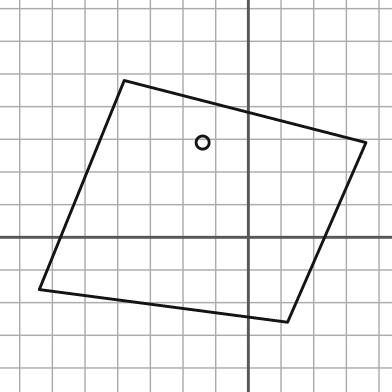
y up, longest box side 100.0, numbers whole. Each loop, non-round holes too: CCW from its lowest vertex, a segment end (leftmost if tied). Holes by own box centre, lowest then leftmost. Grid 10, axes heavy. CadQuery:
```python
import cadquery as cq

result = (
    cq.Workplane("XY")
    .moveTo(12.0, -26.0)
    .lineTo(36.0, 29.0)
    .lineTo(-38.0, 48.0)
    .lineTo(-64.0, -16.0)
    .close()
    .moveTo(-14.0, 29.0)
    .circle(2.0)
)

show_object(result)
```